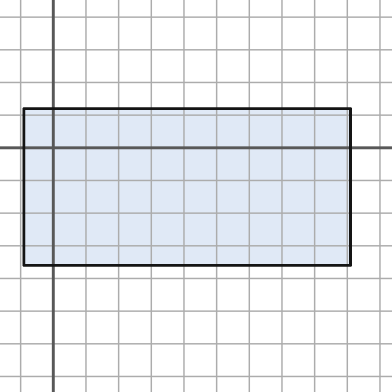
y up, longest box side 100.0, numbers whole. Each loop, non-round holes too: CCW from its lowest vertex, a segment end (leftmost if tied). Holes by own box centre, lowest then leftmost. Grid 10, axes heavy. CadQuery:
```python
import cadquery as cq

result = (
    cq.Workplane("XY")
    .moveTo(-9.0, -36.0)
    .lineTo(91.0, -36.0)
    .lineTo(91.0, 12.0)
    .lineTo(-9.0, 12.0)
    .close()
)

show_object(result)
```